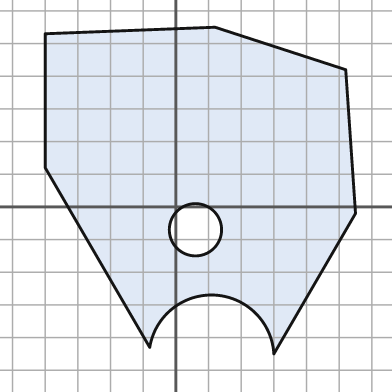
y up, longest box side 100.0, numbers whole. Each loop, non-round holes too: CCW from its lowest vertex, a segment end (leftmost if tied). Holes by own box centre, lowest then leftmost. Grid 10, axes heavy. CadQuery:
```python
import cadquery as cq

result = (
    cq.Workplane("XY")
    .moveTo(30.0, -45.0)
    .lineTo(55.0, -2.0)
    .lineTo(52.0, 42.0)
    .lineTo(12.0, 55.0)
    .lineTo(-40.0, 53.0)
    .lineTo(-40.0, 12.0)
    .lineTo(-8.0, -43.0)
    .threePointArc((12.0, -27.0), (30.0, -45.0))
    .close()
    .moveTo(6.0, -7.0)
    .circle(8.0)
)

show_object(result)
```